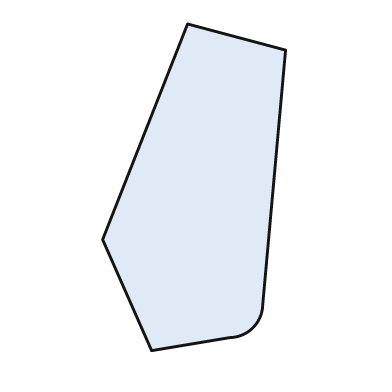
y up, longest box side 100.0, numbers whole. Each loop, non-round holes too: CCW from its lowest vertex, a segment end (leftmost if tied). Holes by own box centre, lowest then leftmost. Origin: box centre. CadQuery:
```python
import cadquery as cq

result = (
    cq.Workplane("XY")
    .moveTo(-13.0, -50.0)
    .lineTo(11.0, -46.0)
    .threePointArc((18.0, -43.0), (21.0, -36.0))
    .lineTo(28.0, 42.0)
    .lineTo(-2.0, 50.0)
    .lineTo(-28.0, -16.0)
    .close()
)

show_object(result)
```